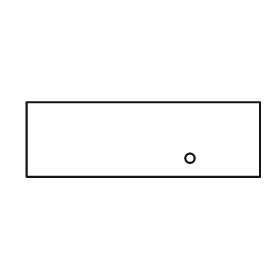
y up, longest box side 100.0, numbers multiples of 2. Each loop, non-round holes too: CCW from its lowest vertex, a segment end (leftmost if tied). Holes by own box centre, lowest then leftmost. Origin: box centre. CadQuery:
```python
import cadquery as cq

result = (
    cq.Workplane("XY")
    .moveTo(-50.0, -16.0)
    .lineTo(50.0, -16.0)
    .lineTo(50.0, 16.0)
    .lineTo(-50.0, 16.0)
    .close()
    .moveTo(20.0, -8.0)
    .circle(2.0)
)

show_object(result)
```